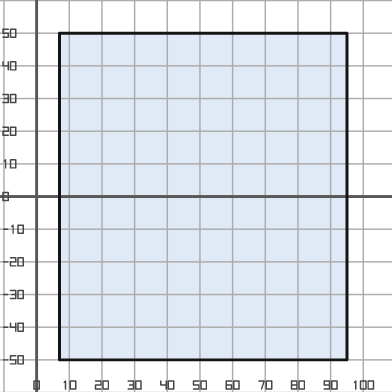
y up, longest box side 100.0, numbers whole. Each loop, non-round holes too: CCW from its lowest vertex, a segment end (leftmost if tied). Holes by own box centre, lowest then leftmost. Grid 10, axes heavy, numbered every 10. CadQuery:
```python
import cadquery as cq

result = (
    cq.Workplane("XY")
    .moveTo(7.0, -50.0)
    .lineTo(95.0, -50.0)
    .lineTo(95.0, 50.0)
    .lineTo(7.0, 50.0)
    .close()
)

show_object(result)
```